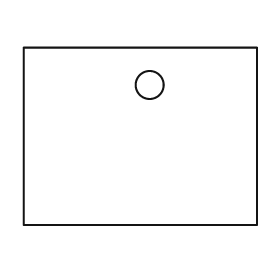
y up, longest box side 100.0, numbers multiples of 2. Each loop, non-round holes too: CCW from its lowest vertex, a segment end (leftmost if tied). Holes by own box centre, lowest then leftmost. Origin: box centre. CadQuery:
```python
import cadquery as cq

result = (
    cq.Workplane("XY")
    .moveTo(-50.0, -38.0)
    .lineTo(50.0, -38.0)
    .lineTo(50.0, 38.0)
    .lineTo(-50.0, 38.0)
    .close()
    .moveTo(4.0, 22.0)
    .circle(6.0)
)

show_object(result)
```